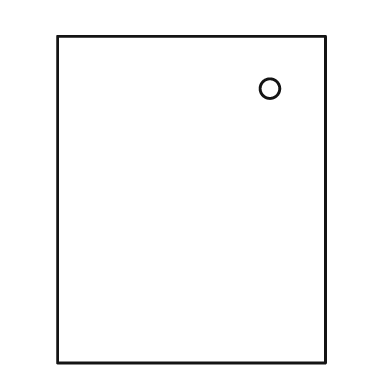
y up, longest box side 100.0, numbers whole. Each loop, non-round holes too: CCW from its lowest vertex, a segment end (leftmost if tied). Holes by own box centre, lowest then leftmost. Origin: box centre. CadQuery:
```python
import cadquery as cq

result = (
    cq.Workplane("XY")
    .moveTo(-41.0, -50.0)
    .lineTo(41.0, -50.0)
    .lineTo(41.0, 50.0)
    .lineTo(-41.0, 50.0)
    .close()
    .moveTo(24.0, 34.0)
    .circle(3.0)
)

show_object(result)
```